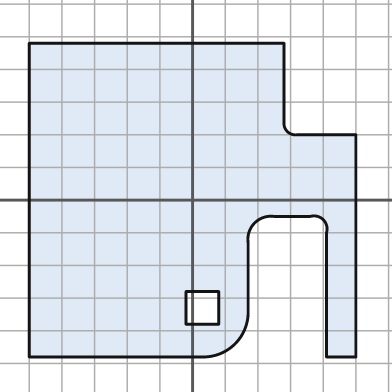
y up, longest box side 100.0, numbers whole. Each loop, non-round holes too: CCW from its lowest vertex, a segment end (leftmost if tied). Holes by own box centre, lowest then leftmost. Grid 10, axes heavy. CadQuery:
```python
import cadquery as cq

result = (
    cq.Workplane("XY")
    .moveTo(-50.0, -48.0)
    .lineTo(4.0, -48.0)
    .threePointArc((13.0, -44.0), (17.0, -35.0))
    .lineTo(17.0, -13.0)
    .threePointArc((19.0, -7.0), (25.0, -5.0))
    .lineTo(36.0, -5.0)
    .threePointArc((40.0, -6.0), (41.0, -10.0))
    .lineTo(41.0, -48.0)
    .lineTo(50.0, -48.0)
    .lineTo(50.0, 20.0)
    .lineTo(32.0, 20.0)
    .threePointArc((29.0, 21.0), (28.0, 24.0))
    .lineTo(28.0, 48.0)
    .lineTo(-50.0, 48.0)
    .close()
    .moveTo(-2.0, -38.0)
    .lineTo(8.0, -38.0)
    .lineTo(8.0, -28.0)
    .lineTo(-2.0, -28.0)
    .close()
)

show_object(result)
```